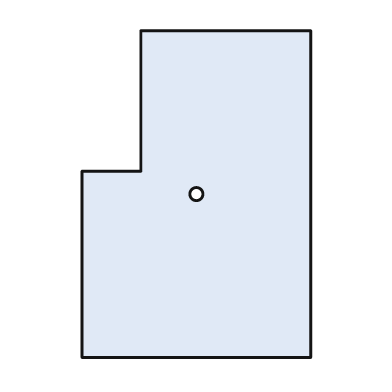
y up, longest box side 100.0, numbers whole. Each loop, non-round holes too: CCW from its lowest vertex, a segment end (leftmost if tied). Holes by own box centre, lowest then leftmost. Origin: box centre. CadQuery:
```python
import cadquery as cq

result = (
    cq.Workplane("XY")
    .moveTo(-35.0, -50.0)
    .lineTo(35.0, -50.0)
    .lineTo(35.0, 50.0)
    .lineTo(-17.0, 50.0)
    .lineTo(-17.0, 7.0)
    .lineTo(-35.0, 7.0)
    .close()
    .moveTo(0.0, 0.0)
    .circle(2.0)
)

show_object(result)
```